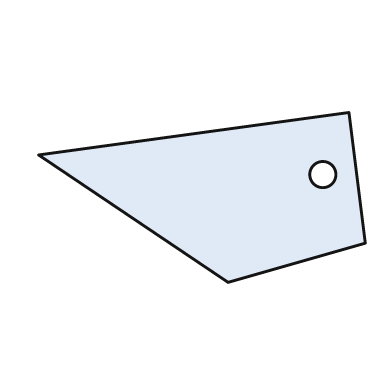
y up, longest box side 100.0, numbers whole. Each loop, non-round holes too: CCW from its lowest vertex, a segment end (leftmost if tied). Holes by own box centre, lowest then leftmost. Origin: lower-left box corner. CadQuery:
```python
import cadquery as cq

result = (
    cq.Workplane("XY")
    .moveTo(58.0, 0.0)
    .lineTo(100.0, 12.0)
    .lineTo(95.0, 52.0)
    .lineTo(0.0, 39.0)
    .close()
    .moveTo(87.0, 33.0)
    .circle(4.0)
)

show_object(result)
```